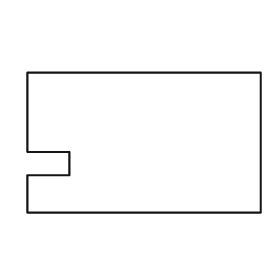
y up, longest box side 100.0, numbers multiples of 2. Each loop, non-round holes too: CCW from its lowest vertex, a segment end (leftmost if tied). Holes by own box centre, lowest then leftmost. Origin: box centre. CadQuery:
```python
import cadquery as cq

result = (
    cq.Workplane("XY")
    .moveTo(-50.0, -30.0)
    .lineTo(50.0, -30.0)
    .lineTo(50.0, 30.0)
    .lineTo(-50.0, 30.0)
    .lineTo(-50.0, -4.0)
    .lineTo(-32.0, -4.0)
    .lineTo(-32.0, -14.0)
    .lineTo(-50.0, -14.0)
    .close()
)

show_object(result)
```